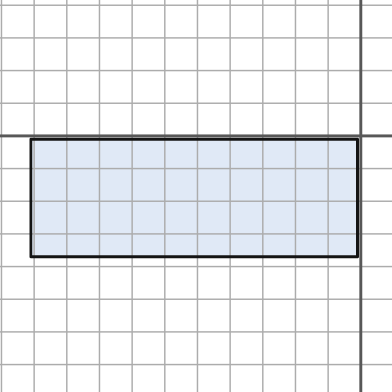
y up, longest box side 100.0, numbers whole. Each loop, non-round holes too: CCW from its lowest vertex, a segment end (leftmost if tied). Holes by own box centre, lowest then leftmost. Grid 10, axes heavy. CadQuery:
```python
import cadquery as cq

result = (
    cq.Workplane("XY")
    .moveTo(-101.0, -37.0)
    .lineTo(-1.0, -37.0)
    .lineTo(-1.0, -1.0)
    .lineTo(-101.0, -1.0)
    .close()
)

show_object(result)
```